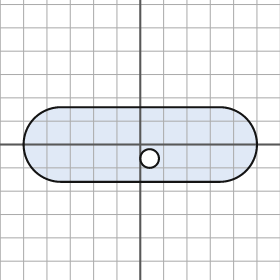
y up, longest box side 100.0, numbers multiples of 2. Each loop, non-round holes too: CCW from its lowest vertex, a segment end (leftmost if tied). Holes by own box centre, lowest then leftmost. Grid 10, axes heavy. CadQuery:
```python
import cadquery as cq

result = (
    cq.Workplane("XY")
    .moveTo(-34.0, -16.0)
    .lineTo(34.0, -16.0)
    .threePointArc((50.0, 0.0), (34.0, 16.0))
    .lineTo(-34.0, 16.0)
    .threePointArc((-50.0, 0.0), (-34.0, -16.0))
    .close()
    .moveTo(4.0, -6.0)
    .circle(4.0)
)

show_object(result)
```